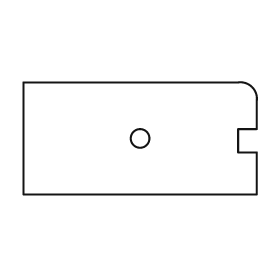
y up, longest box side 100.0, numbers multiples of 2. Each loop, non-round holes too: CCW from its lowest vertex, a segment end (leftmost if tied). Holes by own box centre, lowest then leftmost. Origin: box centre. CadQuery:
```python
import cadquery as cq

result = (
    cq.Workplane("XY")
    .moveTo(-50.0, -24.0)
    .lineTo(50.0, -24.0)
    .lineTo(50.0, -6.0)
    .lineTo(42.0, -6.0)
    .lineTo(42.0, 4.0)
    .lineTo(50.0, 4.0)
    .lineTo(50.0, 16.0)
    .threePointArc((48.0, 22.0), (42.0, 24.0))
    .lineTo(-50.0, 24.0)
    .close()
    .moveTo(0.0, 0.0)
    .circle(4.0)
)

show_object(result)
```